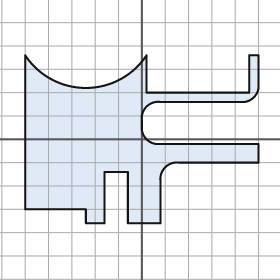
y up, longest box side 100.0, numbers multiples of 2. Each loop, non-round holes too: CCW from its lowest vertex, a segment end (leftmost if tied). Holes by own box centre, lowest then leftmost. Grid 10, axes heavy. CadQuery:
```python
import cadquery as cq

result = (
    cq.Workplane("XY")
    .moveTo(-24.0, -36.0)
    .lineTo(-16.0, -36.0)
    .lineTo(-16.0, -14.0)
    .lineTo(-6.0, -14.0)
    .lineTo(-6.0, -36.0)
    .lineTo(8.0, -36.0)
    .lineTo(8.0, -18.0)
    .threePointArc((10.0, -12.0), (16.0, -10.0))
    .lineTo(50.0, -10.0)
    .lineTo(50.0, -2.0)
    .lineTo(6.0, -2.0)
    .threePointArc((2.0, 0.0), (0.0, 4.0))
    .lineTo(0.0, 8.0)
    .threePointArc((2.0, 14.0), (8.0, 16.0))
    .lineTo(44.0, 16.0)
    .threePointArc((48.0, 18.0), (50.0, 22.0))
    .lineTo(50.0, 36.0)
    .lineTo(46.0, 36.0)
    .lineTo(46.0, 20.0)
    .lineTo(2.0, 20.0)
    .lineTo(2.0, 36.0)
    .threePointArc((-24.0, 22.0), (-50.0, 36.0))
    .lineTo(-50.0, -30.0)
    .lineTo(-24.0, -30.0)
    .close()
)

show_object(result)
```